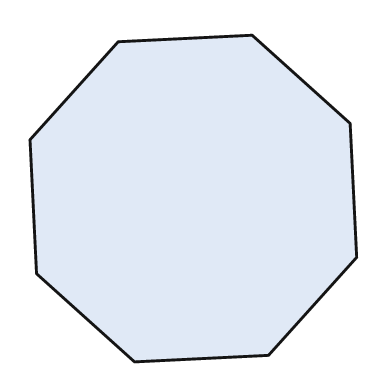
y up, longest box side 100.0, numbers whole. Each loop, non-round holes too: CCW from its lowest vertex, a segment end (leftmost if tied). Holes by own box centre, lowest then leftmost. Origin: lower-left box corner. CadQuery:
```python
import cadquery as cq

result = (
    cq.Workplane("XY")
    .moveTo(32.0, 0.0)
    .lineTo(73.0, 2.0)
    .lineTo(100.0, 32.0)
    .lineTo(98.0, 73.0)
    .lineTo(68.0, 100.0)
    .lineTo(27.0, 98.0)
    .lineTo(0.0, 68.0)
    .lineTo(2.0, 27.0)
    .close()
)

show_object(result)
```